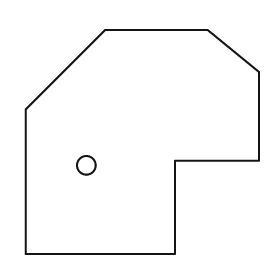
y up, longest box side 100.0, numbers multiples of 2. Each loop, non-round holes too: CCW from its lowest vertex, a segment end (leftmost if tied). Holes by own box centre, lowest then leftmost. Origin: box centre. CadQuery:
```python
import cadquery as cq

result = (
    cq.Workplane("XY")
    .moveTo(-50.0, -48.0)
    .lineTo(14.0, -48.0)
    .lineTo(14.0, -8.0)
    .lineTo(50.0, -8.0)
    .lineTo(50.0, 30.0)
    .lineTo(28.0, 48.0)
    .lineTo(-16.0, 48.0)
    .lineTo(-50.0, 14.0)
    .close()
    .moveTo(-24.0, -10.0)
    .circle(4.0)
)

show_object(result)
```